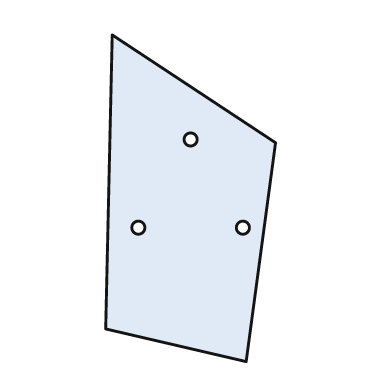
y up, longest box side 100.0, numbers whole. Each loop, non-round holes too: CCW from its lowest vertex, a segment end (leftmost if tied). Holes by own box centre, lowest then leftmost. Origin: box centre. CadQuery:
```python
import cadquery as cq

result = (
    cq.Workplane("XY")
    .moveTo(17.0, -50.0)
    .lineTo(26.0, 17.0)
    .lineTo(-24.0, 50.0)
    .lineTo(-26.0, -40.0)
    .close()
    .moveTo(-16.0, -9.0)
    .circle(2.0)
    .moveTo(16.0, -9.0)
    .circle(2.0)
    .moveTo(0.0, 18.0)
    .circle(2.0)
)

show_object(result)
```